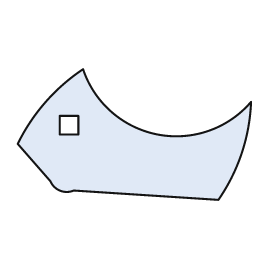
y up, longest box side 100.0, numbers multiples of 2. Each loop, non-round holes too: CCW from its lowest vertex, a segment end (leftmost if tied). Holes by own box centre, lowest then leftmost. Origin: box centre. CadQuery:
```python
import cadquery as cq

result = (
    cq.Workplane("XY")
    .moveTo(36.0, -28.0)
    .threePointArc((46.0, -8.0), (50.0, 14.0))
    .threePointArc((10.0, 0.0), (-22.0, 28.0))
    .threePointArc((-38.0, 14.0), (-50.0, -4.0))
    .lineTo(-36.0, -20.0)
    .threePointArc((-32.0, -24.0), (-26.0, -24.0))
    .close()
    .moveTo(-32.0, 0.0)
    .lineTo(-24.0, 0.0)
    .lineTo(-24.0, 8.0)
    .lineTo(-32.0, 8.0)
    .close()
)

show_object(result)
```